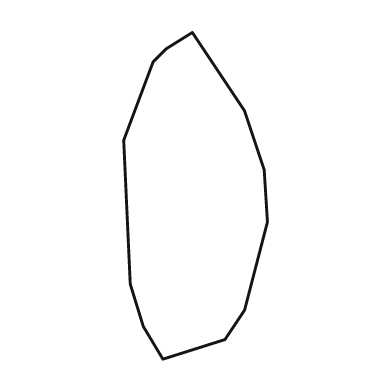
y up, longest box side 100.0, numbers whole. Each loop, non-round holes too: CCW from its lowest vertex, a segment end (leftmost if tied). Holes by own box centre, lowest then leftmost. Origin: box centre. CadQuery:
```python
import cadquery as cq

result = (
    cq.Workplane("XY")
    .moveTo(-10.0, -50.0)
    .lineTo(9.0, -44.0)
    .lineTo(15.0, -35.0)
    .lineTo(22.0, -8.0)
    .lineTo(21.0, 8.0)
    .lineTo(15.0, 26.0)
    .lineTo(-1.0, 50.0)
    .lineTo(-9.0, 45.0)
    .lineTo(-13.0, 41.0)
    .lineTo(-22.0, 17.0)
    .lineTo(-20.0, -27.0)
    .lineTo(-16.0, -40.0)
    .close()
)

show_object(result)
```